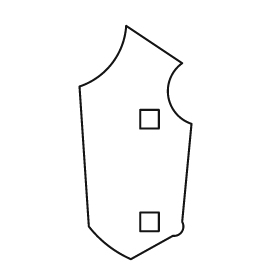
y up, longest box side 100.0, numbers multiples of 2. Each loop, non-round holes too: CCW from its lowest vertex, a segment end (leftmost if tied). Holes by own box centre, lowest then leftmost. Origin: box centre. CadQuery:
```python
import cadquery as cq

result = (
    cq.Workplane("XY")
    .moveTo(-2.0, -50.0)
    .lineTo(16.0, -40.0)
    .threePointArc((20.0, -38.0), (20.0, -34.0))
    .lineTo(24.0, 8.0)
    .threePointArc((14.0, 20.0), (20.0, 34.0))
    .lineTo(-4.0, 50.0)
    .threePointArc((-10.0, 34.0), (-24.0, 24.0))
    .lineTo(-20.0, -36.0)
    .threePointArc((-12.0, -44.0), (-2.0, -50.0))
    .close()
    .moveTo(2.0, -38.0)
    .lineTo(10.0, -38.0)
    .lineTo(10.0, -30.0)
    .lineTo(2.0, -30.0)
    .close()
    .moveTo(2.0, 6.0)
    .lineTo(10.0, 6.0)
    .lineTo(10.0, 14.0)
    .lineTo(2.0, 14.0)
    .close()
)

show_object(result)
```